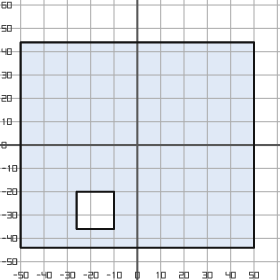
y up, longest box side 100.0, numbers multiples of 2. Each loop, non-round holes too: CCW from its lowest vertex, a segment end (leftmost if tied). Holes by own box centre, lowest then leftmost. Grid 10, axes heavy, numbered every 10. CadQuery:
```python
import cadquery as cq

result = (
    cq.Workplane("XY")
    .moveTo(-50.0, -44.0)
    .lineTo(50.0, -44.0)
    .lineTo(50.0, 44.0)
    .lineTo(-50.0, 44.0)
    .close()
    .moveTo(-26.0, -36.0)
    .lineTo(-10.0, -36.0)
    .lineTo(-10.0, -20.0)
    .lineTo(-26.0, -20.0)
    .close()
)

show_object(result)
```